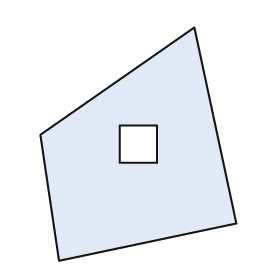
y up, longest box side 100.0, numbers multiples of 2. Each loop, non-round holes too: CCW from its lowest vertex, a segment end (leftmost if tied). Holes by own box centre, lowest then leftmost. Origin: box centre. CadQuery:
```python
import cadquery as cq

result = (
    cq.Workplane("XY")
    .moveTo(-34.0, -50.0)
    .lineTo(42.0, -34.0)
    .lineTo(24.0, 50.0)
    .lineTo(-42.0, 4.0)
    .close()
    .moveTo(-8.0, -8.0)
    .lineTo(8.0, -8.0)
    .lineTo(8.0, 8.0)
    .lineTo(-8.0, 8.0)
    .close()
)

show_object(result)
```